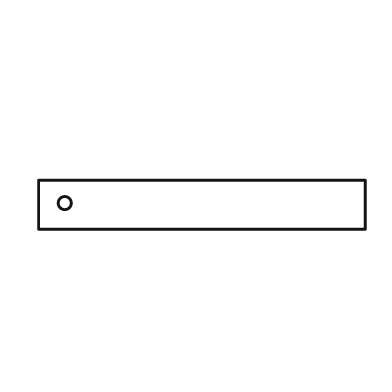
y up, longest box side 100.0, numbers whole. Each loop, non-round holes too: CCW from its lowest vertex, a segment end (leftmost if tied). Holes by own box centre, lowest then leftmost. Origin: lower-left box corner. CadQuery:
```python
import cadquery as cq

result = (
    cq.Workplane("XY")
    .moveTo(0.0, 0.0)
    .lineTo(100.0, 0.0)
    .lineTo(100.0, 15.0)
    .lineTo(0.0, 15.0)
    .close()
    .moveTo(8.0, 8.0)
    .circle(2.0)
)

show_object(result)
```